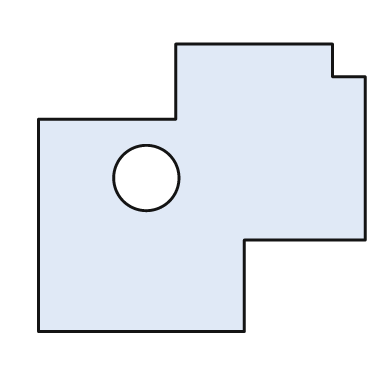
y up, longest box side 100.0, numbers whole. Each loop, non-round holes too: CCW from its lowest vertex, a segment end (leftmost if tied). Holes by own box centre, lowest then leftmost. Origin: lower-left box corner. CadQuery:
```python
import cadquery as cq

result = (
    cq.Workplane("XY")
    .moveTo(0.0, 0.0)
    .lineTo(63.0, 0.0)
    .lineTo(63.0, 28.0)
    .lineTo(100.0, 28.0)
    .lineTo(100.0, 78.0)
    .lineTo(90.0, 78.0)
    .lineTo(90.0, 88.0)
    .lineTo(42.0, 88.0)
    .lineTo(42.0, 65.0)
    .lineTo(0.0, 65.0)
    .close()
    .moveTo(33.0, 47.0)
    .circle(10.0)
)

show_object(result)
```